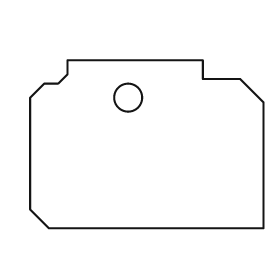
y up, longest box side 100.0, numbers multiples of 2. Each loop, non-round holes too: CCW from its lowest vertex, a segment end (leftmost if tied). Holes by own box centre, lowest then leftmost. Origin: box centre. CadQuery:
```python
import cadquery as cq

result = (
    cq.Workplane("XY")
    .moveTo(-42.0, -36.0)
    .lineTo(50.0, -36.0)
    .lineTo(50.0, 18.0)
    .lineTo(40.0, 28.0)
    .lineTo(24.0, 28.0)
    .lineTo(24.0, 36.0)
    .lineTo(-34.0, 36.0)
    .lineTo(-34.0, 30.0)
    .lineTo(-38.0, 26.0)
    .lineTo(-44.0, 26.0)
    .lineTo(-50.0, 20.0)
    .lineTo(-50.0, -28.0)
    .close()
    .moveTo(-8.0, 20.0)
    .circle(6.0)
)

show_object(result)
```